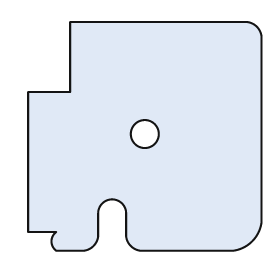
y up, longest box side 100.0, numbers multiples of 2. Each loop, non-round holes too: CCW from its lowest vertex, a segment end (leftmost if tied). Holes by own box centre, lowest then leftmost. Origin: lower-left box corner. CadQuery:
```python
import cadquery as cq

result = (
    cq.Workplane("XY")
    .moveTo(12.0, 0.0)
    .lineTo(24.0, 0.0)
    .threePointArc((28.0, 2.0), (30.0, 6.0))
    .lineTo(30.0, 16.0)
    .threePointArc((36.0, 22.0), (42.0, 16.0))
    .lineTo(42.0, 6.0)
    .threePointArc((44.0, 2.0), (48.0, 0.0))
    .lineTo(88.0, 0.0)
    .threePointArc((96.0, 4.0), (100.0, 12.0))
    .lineTo(100.0, 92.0)
    .threePointArc((98.0, 96.0), (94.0, 98.0))
    .lineTo(18.0, 98.0)
    .lineTo(18.0, 68.0)
    .lineTo(0.0, 68.0)
    .lineTo(0.0, 8.0)
    .lineTo(12.0, 8.0)
    .threePointArc((10.0, 4.0), (12.0, 0.0))
    .close()
    .moveTo(50.0, 50.0)
    .circle(6.0)
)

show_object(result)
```